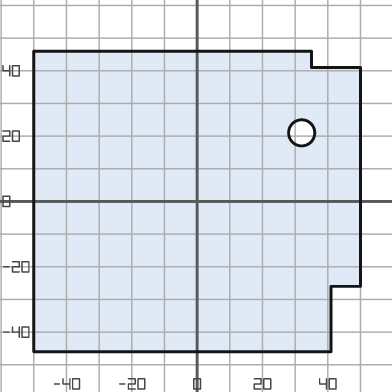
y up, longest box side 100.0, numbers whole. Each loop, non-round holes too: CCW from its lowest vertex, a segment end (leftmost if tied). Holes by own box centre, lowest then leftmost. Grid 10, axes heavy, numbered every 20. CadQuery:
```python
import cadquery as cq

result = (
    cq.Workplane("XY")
    .moveTo(-50.0, -46.0)
    .lineTo(41.0, -46.0)
    .lineTo(41.0, -26.0)
    .lineTo(50.0, -26.0)
    .lineTo(50.0, 41.0)
    .lineTo(35.0, 41.0)
    .lineTo(35.0, 46.0)
    .lineTo(-50.0, 46.0)
    .close()
    .moveTo(32.0, 21.0)
    .circle(4.0)
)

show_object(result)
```